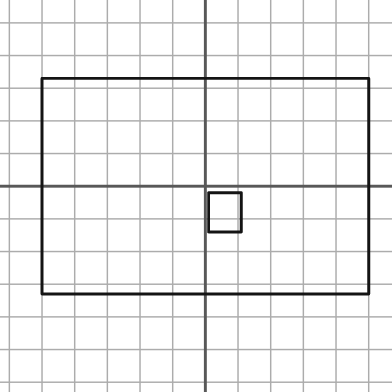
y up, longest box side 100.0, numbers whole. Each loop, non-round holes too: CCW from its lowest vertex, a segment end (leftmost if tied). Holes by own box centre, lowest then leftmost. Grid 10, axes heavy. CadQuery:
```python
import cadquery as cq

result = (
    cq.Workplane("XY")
    .moveTo(-50.0, -33.0)
    .lineTo(50.0, -33.0)
    .lineTo(50.0, 33.0)
    .lineTo(-50.0, 33.0)
    .close()
    .moveTo(1.0, -14.0)
    .lineTo(11.0, -14.0)
    .lineTo(11.0, -2.0)
    .lineTo(1.0, -2.0)
    .close()
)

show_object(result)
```